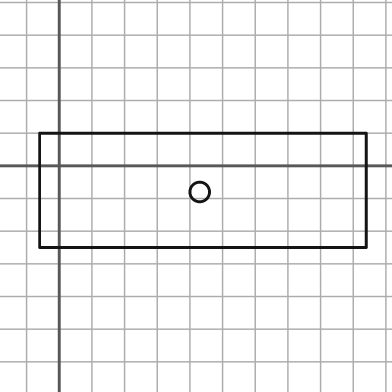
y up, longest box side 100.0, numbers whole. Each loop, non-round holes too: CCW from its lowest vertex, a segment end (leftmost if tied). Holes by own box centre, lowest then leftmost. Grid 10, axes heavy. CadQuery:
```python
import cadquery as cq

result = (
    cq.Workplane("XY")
    .moveTo(-6.0, -25.0)
    .lineTo(94.0, -25.0)
    .lineTo(94.0, 10.0)
    .lineTo(-6.0, 10.0)
    .close()
    .moveTo(43.0, -8.0)
    .circle(3.0)
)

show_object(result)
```